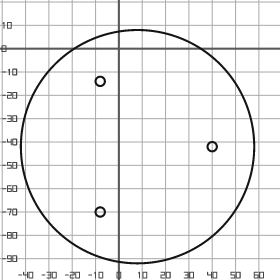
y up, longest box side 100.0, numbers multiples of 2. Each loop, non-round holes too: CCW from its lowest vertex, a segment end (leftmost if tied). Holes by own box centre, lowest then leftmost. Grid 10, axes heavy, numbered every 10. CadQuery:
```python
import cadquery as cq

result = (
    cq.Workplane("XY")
    .moveTo(8.0, -42.0)
    .circle(50.0)
    .moveTo(-8.0, -70.0)
    .circle(2.0)
    .moveTo(40.0, -42.0)
    .circle(2.0)
    .moveTo(-8.0, -14.0)
    .circle(2.0)
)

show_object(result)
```